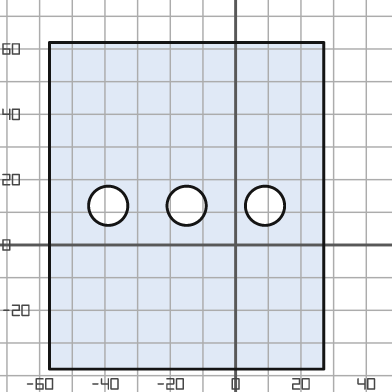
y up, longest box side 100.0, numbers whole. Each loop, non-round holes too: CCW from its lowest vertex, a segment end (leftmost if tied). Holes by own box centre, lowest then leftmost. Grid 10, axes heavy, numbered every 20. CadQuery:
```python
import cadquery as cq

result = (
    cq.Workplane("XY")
    .moveTo(-57.0, -38.0)
    .lineTo(27.0, -38.0)
    .lineTo(27.0, 62.0)
    .lineTo(-57.0, 62.0)
    .close()
    .moveTo(-39.0, 12.0)
    .circle(6.0)
    .moveTo(-15.0, 12.0)
    .circle(6.0)
    .moveTo(9.0, 12.0)
    .circle(6.0)
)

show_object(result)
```